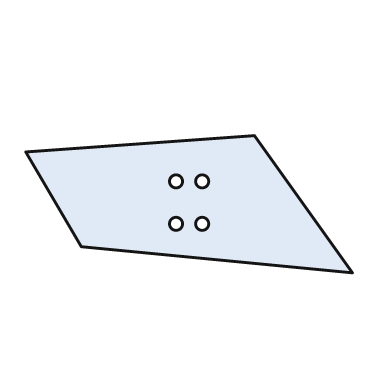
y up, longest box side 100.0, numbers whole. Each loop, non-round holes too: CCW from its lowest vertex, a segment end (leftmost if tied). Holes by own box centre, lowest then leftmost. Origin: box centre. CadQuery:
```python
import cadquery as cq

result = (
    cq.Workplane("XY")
    .moveTo(50.0, -21.0)
    .lineTo(20.0, 21.0)
    .lineTo(-50.0, 16.0)
    .lineTo(-33.0, -13.0)
    .close()
    .moveTo(-4.0, -6.0)
    .circle(2.0)
    .moveTo(4.0, -6.0)
    .circle(2.0)
    .moveTo(-4.0, 7.0)
    .circle(2.0)
    .moveTo(4.0, 7.0)
    .circle(2.0)
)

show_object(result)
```